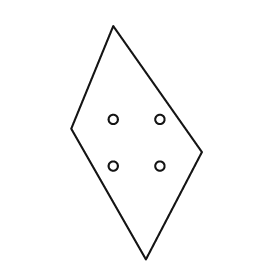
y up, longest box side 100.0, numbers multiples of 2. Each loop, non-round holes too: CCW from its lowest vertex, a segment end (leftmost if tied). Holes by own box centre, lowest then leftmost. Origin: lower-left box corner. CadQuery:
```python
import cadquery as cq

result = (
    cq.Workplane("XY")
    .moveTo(32.0, 0.0)
    .lineTo(56.0, 46.0)
    .lineTo(18.0, 100.0)
    .lineTo(0.0, 56.0)
    .close()
    .moveTo(18.0, 40.0)
    .circle(2.0)
    .moveTo(38.0, 40.0)
    .circle(2.0)
    .moveTo(18.0, 60.0)
    .circle(2.0)
    .moveTo(38.0, 60.0)
    .circle(2.0)
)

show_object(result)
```